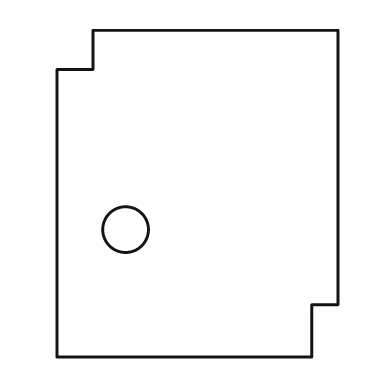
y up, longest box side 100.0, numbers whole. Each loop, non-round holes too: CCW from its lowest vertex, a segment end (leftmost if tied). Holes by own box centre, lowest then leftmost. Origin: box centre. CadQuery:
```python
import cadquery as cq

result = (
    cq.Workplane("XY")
    .moveTo(-43.0, -50.0)
    .lineTo(35.0, -50.0)
    .lineTo(35.0, -34.0)
    .lineTo(43.0, -34.0)
    .lineTo(43.0, 50.0)
    .lineTo(-32.0, 50.0)
    .lineTo(-32.0, 38.0)
    .lineTo(-43.0, 38.0)
    .close()
    .moveTo(-22.0, -11.0)
    .circle(7.0)
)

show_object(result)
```